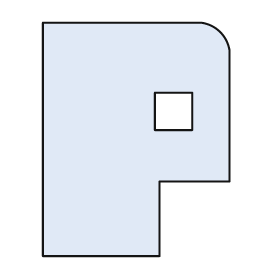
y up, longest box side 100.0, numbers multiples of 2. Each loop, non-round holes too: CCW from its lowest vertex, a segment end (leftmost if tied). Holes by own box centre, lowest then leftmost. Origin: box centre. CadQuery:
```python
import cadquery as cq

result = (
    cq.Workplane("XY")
    .moveTo(-40.0, -50.0)
    .lineTo(10.0, -50.0)
    .lineTo(10.0, -18.0)
    .lineTo(40.0, -18.0)
    .lineTo(40.0, 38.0)
    .threePointArc((36.0, 46.0), (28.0, 50.0))
    .lineTo(-40.0, 50.0)
    .close()
    .moveTo(8.0, 4.0)
    .lineTo(24.0, 4.0)
    .lineTo(24.0, 20.0)
    .lineTo(8.0, 20.0)
    .close()
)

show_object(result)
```